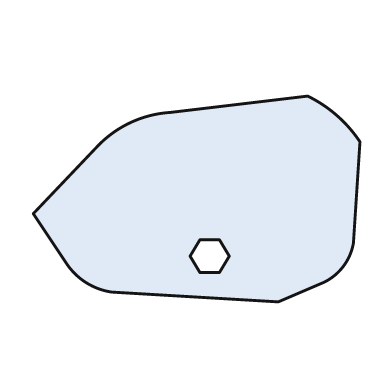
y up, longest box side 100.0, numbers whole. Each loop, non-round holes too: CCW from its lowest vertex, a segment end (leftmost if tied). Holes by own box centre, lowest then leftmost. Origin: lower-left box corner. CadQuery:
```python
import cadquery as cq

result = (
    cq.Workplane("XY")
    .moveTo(75.0, 0.0)
    .lineTo(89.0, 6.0)
    .threePointArc((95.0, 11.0), (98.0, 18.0))
    .lineTo(100.0, 49.0)
    .threePointArc((93.0, 57.0), (84.0, 63.0))
    .lineTo(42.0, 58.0)
    .threePointArc((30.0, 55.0), (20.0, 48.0))
    .lineTo(0.0, 27.0)
    .lineTo(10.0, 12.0)
    .threePointArc((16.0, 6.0), (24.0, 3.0))
    .close()
    .moveTo(51.0, 9.0)
    .lineTo(57.0, 9.0)
    .lineTo(60.0, 14.0)
    .lineTo(57.0, 19.0)
    .lineTo(51.0, 19.0)
    .lineTo(48.0, 14.0)
    .close()
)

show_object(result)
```